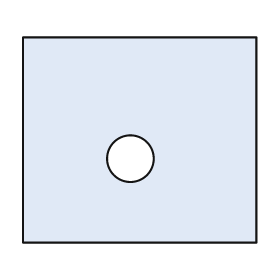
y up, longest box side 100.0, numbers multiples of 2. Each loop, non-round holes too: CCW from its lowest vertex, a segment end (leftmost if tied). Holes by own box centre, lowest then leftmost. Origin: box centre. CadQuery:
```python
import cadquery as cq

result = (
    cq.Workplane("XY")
    .moveTo(-50.0, -44.0)
    .lineTo(50.0, -44.0)
    .lineTo(50.0, 44.0)
    .lineTo(-50.0, 44.0)
    .close()
    .moveTo(-4.0, -8.0)
    .circle(10.0)
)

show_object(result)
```